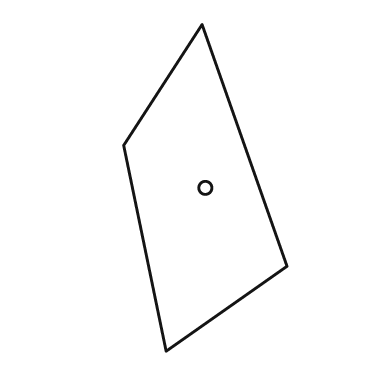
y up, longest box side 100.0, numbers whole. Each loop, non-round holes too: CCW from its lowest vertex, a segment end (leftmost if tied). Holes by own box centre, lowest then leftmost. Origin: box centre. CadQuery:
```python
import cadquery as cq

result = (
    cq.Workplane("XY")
    .moveTo(-12.0, -50.0)
    .lineTo(25.0, -24.0)
    .lineTo(-1.0, 50.0)
    .lineTo(-25.0, 13.0)
    .close()
    .moveTo(0.0, 0.0)
    .circle(2.0)
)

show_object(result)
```